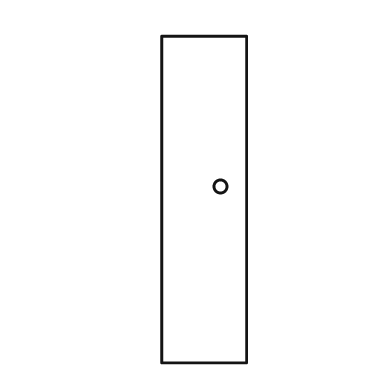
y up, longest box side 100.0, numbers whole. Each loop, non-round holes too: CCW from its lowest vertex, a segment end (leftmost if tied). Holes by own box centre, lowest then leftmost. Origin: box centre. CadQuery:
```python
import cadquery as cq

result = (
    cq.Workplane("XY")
    .moveTo(-13.0, -50.0)
    .lineTo(13.0, -50.0)
    .lineTo(13.0, 50.0)
    .lineTo(-13.0, 50.0)
    .close()
    .moveTo(5.0, 4.0)
    .circle(2.0)
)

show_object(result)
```